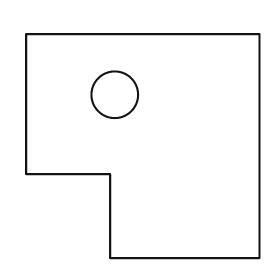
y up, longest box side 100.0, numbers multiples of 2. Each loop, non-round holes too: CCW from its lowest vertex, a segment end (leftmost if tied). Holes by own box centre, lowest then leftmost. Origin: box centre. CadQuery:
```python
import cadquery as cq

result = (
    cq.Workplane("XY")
    .moveTo(-14.0, -48.0)
    .lineTo(50.0, -48.0)
    .lineTo(50.0, 48.0)
    .lineTo(-50.0, 48.0)
    .lineTo(-50.0, -12.0)
    .lineTo(-14.0, -12.0)
    .close()
    .moveTo(-12.0, 22.0)
    .circle(10.0)
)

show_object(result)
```